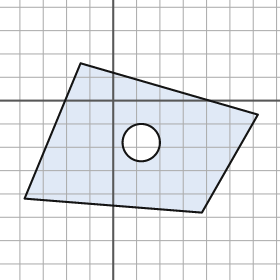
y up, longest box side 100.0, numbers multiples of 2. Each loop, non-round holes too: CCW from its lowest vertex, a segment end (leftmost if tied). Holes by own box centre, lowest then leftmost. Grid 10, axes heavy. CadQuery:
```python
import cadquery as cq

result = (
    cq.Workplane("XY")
    .moveTo(38.0, -48.0)
    .lineTo(62.0, -6.0)
    .lineTo(-14.0, 16.0)
    .lineTo(-38.0, -42.0)
    .close()
    .moveTo(12.0, -18.0)
    .circle(8.0)
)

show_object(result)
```